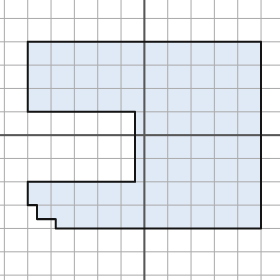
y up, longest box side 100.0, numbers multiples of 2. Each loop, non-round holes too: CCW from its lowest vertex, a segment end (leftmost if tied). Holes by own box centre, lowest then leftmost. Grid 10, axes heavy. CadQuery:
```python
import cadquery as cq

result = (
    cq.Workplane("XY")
    .moveTo(-38.0, -40.0)
    .lineTo(50.0, -40.0)
    .lineTo(50.0, 40.0)
    .lineTo(-50.0, 40.0)
    .lineTo(-50.0, 10.0)
    .lineTo(-4.0, 10.0)
    .lineTo(-4.0, -20.0)
    .lineTo(-50.0, -20.0)
    .lineTo(-50.0, -30.0)
    .lineTo(-46.0, -30.0)
    .lineTo(-46.0, -36.0)
    .lineTo(-38.0, -36.0)
    .close()
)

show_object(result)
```